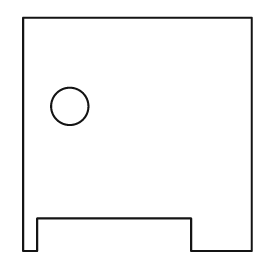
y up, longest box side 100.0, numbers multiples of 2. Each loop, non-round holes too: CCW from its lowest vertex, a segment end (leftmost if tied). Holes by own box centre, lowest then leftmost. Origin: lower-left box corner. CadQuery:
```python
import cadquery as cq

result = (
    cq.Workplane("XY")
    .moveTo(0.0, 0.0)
    .lineTo(6.0, 0.0)
    .lineTo(6.0, 14.0)
    .lineTo(72.0, 14.0)
    .lineTo(72.0, 0.0)
    .lineTo(98.0, 0.0)
    .lineTo(98.0, 100.0)
    .lineTo(0.0, 100.0)
    .close()
    .moveTo(20.0, 62.0)
    .circle(8.0)
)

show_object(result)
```